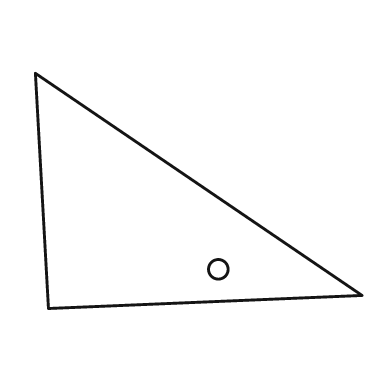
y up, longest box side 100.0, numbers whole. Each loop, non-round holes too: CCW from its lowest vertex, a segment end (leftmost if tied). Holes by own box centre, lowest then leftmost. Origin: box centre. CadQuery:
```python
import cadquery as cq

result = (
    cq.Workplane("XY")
    .moveTo(-46.0, -36.0)
    .lineTo(50.0, -32.0)
    .lineTo(-50.0, 36.0)
    .close()
    .moveTo(6.0, -24.0)
    .circle(3.0)
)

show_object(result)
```